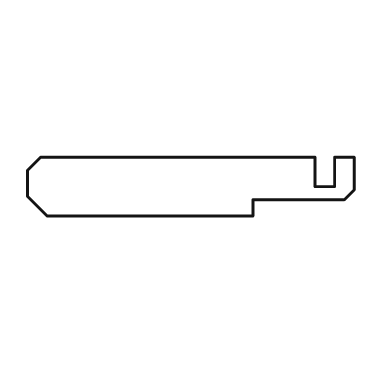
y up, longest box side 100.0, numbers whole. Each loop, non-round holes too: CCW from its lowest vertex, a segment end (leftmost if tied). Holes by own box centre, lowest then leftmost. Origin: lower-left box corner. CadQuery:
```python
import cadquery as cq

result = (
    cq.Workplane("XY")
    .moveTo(6.0, 0.0)
    .lineTo(69.0, 0.0)
    .lineTo(69.0, 5.0)
    .lineTo(97.0, 5.0)
    .lineTo(100.0, 8.0)
    .lineTo(100.0, 18.0)
    .lineTo(94.0, 18.0)
    .lineTo(94.0, 9.0)
    .lineTo(88.0, 9.0)
    .lineTo(88.0, 18.0)
    .lineTo(4.0, 18.0)
    .lineTo(0.0, 14.0)
    .lineTo(0.0, 6.0)
    .close()
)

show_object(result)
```